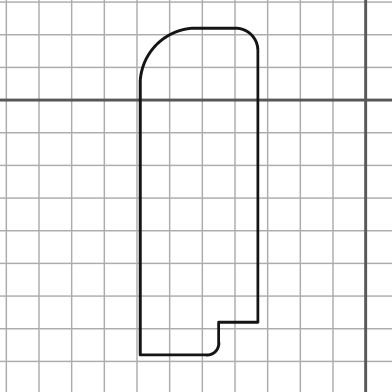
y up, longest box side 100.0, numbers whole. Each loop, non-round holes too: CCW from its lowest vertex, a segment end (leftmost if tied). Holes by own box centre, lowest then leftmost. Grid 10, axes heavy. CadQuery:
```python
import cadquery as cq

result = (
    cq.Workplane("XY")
    .moveTo(-69.0, -78.0)
    .lineTo(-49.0, -78.0)
    .threePointArc((-46.0, -77.0), (-45.0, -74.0))
    .lineTo(-45.0, -68.0)
    .lineTo(-33.0, -68.0)
    .lineTo(-33.0, 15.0)
    .threePointArc((-35.0, 20.0), (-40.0, 22.0))
    .lineTo(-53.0, 22.0)
    .threePointArc((-64.0, 17.0), (-69.0, 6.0))
    .close()
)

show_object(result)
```